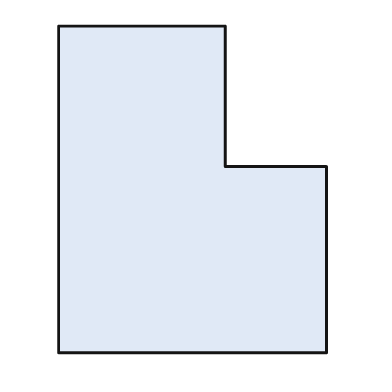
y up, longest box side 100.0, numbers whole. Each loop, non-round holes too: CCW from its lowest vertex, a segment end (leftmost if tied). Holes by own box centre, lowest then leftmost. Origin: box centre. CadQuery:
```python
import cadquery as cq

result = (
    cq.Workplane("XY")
    .moveTo(-41.0, -50.0)
    .lineTo(41.0, -50.0)
    .lineTo(41.0, 7.0)
    .lineTo(10.0, 7.0)
    .lineTo(10.0, 50.0)
    .lineTo(-41.0, 50.0)
    .close()
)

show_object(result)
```